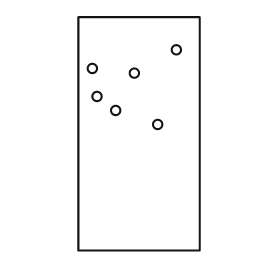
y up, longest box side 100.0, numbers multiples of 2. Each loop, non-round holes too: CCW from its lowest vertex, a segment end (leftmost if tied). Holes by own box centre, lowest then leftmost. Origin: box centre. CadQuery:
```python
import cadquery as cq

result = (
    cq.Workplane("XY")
    .moveTo(-26.0, -50.0)
    .lineTo(26.0, -50.0)
    .lineTo(26.0, 50.0)
    .lineTo(-26.0, 50.0)
    .close()
    .moveTo(8.0, 4.0)
    .circle(2.0)
    .moveTo(-10.0, 10.0)
    .circle(2.0)
    .moveTo(-18.0, 16.0)
    .circle(2.0)
    .moveTo(-2.0, 26.0)
    .circle(2.0)
    .moveTo(-20.0, 28.0)
    .circle(2.0)
    .moveTo(16.0, 36.0)
    .circle(2.0)
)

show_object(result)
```